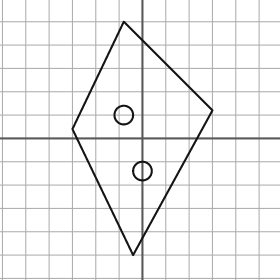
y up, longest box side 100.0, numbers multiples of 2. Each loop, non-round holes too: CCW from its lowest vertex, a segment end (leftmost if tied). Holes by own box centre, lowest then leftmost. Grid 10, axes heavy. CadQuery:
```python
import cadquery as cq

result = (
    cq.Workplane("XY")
    .moveTo(-4.0, -50.0)
    .lineTo(30.0, 12.0)
    .lineTo(-8.0, 50.0)
    .lineTo(-30.0, 4.0)
    .close()
    .moveTo(0.0, -14.0)
    .circle(4.0)
    .moveTo(-8.0, 10.0)
    .circle(4.0)
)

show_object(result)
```